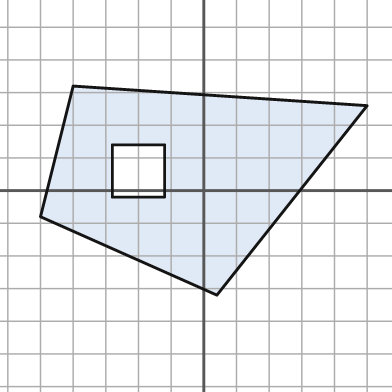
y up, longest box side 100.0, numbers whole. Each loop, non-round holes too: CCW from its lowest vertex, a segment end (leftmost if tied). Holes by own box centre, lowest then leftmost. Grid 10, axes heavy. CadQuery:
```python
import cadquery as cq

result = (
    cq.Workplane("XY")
    .moveTo(4.0, -32.0)
    .lineTo(50.0, 26.0)
    .lineTo(-40.0, 32.0)
    .lineTo(-50.0, -8.0)
    .close()
    .moveTo(-28.0, -2.0)
    .lineTo(-12.0, -2.0)
    .lineTo(-12.0, 14.0)
    .lineTo(-28.0, 14.0)
    .close()
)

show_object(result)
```